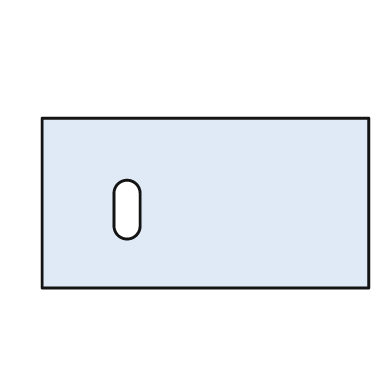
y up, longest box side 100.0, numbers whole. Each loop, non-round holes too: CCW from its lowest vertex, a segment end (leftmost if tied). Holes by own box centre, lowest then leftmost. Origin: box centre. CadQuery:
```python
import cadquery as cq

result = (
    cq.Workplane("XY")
    .moveTo(-50.0, -26.0)
    .lineTo(50.0, -26.0)
    .lineTo(50.0, 26.0)
    .lineTo(-50.0, 26.0)
    .close()
    .moveTo(-28.0, -7.0)
    .threePointArc((-24.0, -11.0), (-20.0, -7.0))
    .lineTo(-20.0, 3.0)
    .threePointArc((-24.0, 7.0), (-28.0, 3.0))
    .close()
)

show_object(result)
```